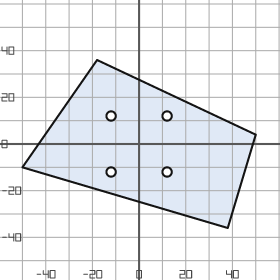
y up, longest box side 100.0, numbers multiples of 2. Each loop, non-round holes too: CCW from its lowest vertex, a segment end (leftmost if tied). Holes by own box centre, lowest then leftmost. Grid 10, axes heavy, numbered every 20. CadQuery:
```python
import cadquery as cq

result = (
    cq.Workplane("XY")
    .moveTo(38.0, -36.0)
    .lineTo(50.0, 4.0)
    .lineTo(-18.0, 36.0)
    .lineTo(-50.0, -10.0)
    .close()
    .moveTo(-12.0, -12.0)
    .circle(2.0)
    .moveTo(12.0, -12.0)
    .circle(2.0)
    .moveTo(-12.0, 12.0)
    .circle(2.0)
    .moveTo(12.0, 12.0)
    .circle(2.0)
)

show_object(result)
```